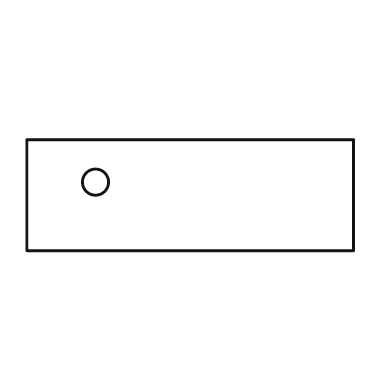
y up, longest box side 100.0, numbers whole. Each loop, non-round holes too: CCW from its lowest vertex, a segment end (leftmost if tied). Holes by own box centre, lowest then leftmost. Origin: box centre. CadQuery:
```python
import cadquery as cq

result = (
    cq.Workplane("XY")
    .moveTo(-50.0, -17.0)
    .lineTo(50.0, -17.0)
    .lineTo(50.0, 17.0)
    .lineTo(-50.0, 17.0)
    .close()
    .moveTo(-29.0, 4.0)
    .circle(4.0)
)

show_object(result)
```